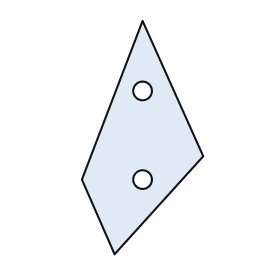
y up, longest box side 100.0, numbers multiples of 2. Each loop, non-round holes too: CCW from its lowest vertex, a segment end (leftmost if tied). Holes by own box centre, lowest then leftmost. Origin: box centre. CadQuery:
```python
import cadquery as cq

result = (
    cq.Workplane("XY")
    .moveTo(-12.0, -50.0)
    .lineTo(26.0, -8.0)
    .lineTo(0.0, 50.0)
    .lineTo(-26.0, -18.0)
    .close()
    .moveTo(0.0, -18.0)
    .circle(4.0)
    .moveTo(0.0, 20.0)
    .circle(4.0)
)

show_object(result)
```